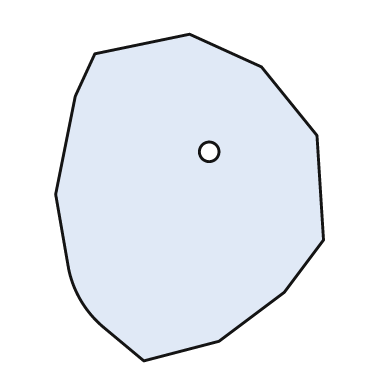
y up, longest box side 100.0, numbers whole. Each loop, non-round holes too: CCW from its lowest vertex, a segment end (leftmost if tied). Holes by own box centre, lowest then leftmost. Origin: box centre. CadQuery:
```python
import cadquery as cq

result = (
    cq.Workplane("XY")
    .moveTo(-14.0, -50.0)
    .lineTo(9.0, -44.0)
    .lineTo(29.0, -29.0)
    .lineTo(41.0, -13.0)
    .lineTo(39.0, 19.0)
    .lineTo(22.0, 40.0)
    .lineTo(0.0, 50.0)
    .lineTo(-29.0, 44.0)
    .lineTo(-35.0, 31.0)
    .lineTo(-41.0, 1.0)
    .lineTo(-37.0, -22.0)
    .threePointArc((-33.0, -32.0), (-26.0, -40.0))
    .close()
    .moveTo(6.0, 14.0)
    .circle(3.0)
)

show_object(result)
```